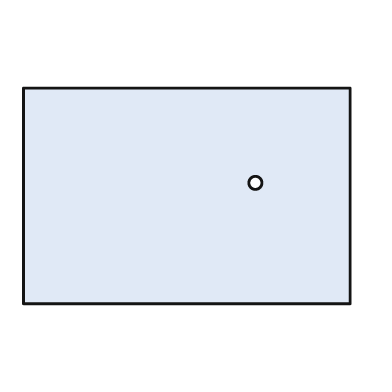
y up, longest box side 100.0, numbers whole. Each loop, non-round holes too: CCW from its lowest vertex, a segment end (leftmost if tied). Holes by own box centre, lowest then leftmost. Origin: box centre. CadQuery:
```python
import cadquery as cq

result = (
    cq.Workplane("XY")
    .moveTo(-50.0, -33.0)
    .lineTo(50.0, -33.0)
    .lineTo(50.0, 33.0)
    .lineTo(-50.0, 33.0)
    .close()
    .moveTo(21.0, 4.0)
    .circle(2.0)
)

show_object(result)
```